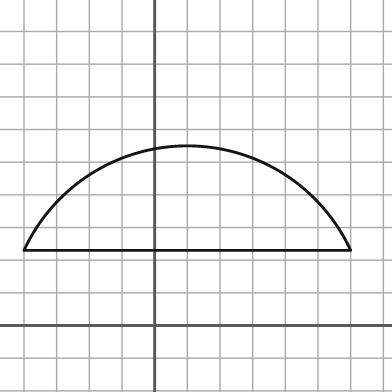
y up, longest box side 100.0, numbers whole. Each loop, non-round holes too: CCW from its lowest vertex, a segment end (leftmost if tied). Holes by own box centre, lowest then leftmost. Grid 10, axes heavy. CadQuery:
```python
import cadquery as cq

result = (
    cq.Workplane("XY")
    .moveTo(-40.0, 23.0)
    .lineTo(60.0, 23.0)
    .threePointArc((10.0, 55.0), (-40.0, 23.0))
    .close()
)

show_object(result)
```